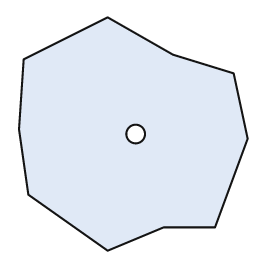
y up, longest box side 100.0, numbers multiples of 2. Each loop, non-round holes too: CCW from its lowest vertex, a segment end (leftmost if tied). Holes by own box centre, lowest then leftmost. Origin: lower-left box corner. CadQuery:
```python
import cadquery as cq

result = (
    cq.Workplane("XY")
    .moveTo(38.0, 0.0)
    .lineTo(62.0, 10.0)
    .lineTo(84.0, 10.0)
    .lineTo(98.0, 48.0)
    .lineTo(92.0, 76.0)
    .lineTo(66.0, 84.0)
    .lineTo(38.0, 100.0)
    .lineTo(2.0, 82.0)
    .lineTo(0.0, 52.0)
    .lineTo(4.0, 24.0)
    .close()
    .moveTo(50.0, 50.0)
    .circle(4.0)
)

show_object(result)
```